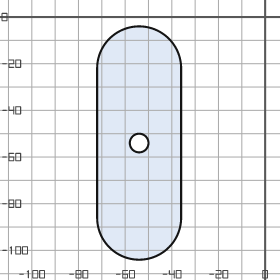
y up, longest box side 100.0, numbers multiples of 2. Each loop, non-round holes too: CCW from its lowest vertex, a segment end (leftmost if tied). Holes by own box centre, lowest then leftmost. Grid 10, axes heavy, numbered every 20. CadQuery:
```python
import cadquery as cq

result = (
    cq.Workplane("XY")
    .moveTo(-72.0, -86.0)
    .threePointArc((-54.0, -104.0), (-36.0, -86.0))
    .lineTo(-36.0, -22.0)
    .threePointArc((-54.0, -4.0), (-72.0, -22.0))
    .close()
    .moveTo(-54.0, -54.0)
    .circle(4.0)
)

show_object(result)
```